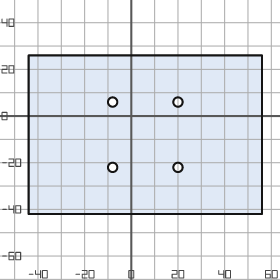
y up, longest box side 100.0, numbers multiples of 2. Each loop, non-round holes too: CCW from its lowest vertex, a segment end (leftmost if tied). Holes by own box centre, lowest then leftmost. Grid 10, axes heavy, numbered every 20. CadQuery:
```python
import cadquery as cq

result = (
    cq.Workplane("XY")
    .moveTo(-44.0, -42.0)
    .lineTo(56.0, -42.0)
    .lineTo(56.0, 26.0)
    .lineTo(-44.0, 26.0)
    .close()
    .moveTo(-8.0, -22.0)
    .circle(2.0)
    .moveTo(20.0, -22.0)
    .circle(2.0)
    .moveTo(-8.0, 6.0)
    .circle(2.0)
    .moveTo(20.0, 6.0)
    .circle(2.0)
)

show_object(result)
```